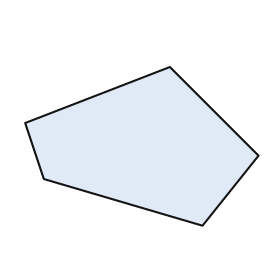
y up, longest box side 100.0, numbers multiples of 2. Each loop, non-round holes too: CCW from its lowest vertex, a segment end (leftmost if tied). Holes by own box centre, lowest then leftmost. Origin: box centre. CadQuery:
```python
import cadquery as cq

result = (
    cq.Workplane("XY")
    .moveTo(26.0, -34.0)
    .lineTo(50.0, -4.0)
    .lineTo(12.0, 34.0)
    .lineTo(-50.0, 10.0)
    .lineTo(-42.0, -14.0)
    .close()
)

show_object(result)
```